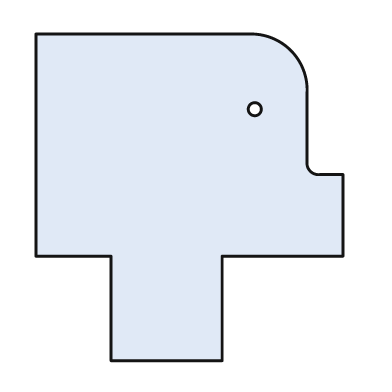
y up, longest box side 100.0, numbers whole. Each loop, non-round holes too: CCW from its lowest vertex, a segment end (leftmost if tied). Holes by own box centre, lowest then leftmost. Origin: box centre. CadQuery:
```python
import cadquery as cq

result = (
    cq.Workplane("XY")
    .moveTo(-24.0, -50.0)
    .lineTo(10.0, -50.0)
    .lineTo(10.0, -18.0)
    .lineTo(47.0, -18.0)
    .lineTo(47.0, 7.0)
    .lineTo(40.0, 7.0)
    .threePointArc((37.0, 8.0), (36.0, 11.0))
    .lineTo(36.0, 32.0)
    .threePointArc((31.0, 45.0), (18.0, 50.0))
    .lineTo(-47.0, 50.0)
    .lineTo(-47.0, -18.0)
    .lineTo(-24.0, -18.0)
    .close()
    .moveTo(20.0, 27.0)
    .circle(2.0)
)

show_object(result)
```